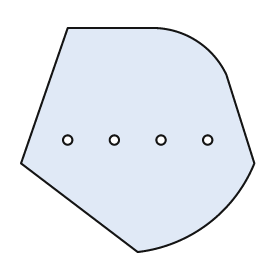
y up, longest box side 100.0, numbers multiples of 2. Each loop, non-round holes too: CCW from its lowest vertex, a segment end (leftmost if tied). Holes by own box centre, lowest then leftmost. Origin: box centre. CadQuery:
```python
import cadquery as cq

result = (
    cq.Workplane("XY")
    .moveTo(0.0, -48.0)
    .threePointArc((30.0, -36.0), (50.0, -10.0))
    .lineTo(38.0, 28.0)
    .threePointArc((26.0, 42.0), (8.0, 48.0))
    .lineTo(-30.0, 48.0)
    .lineTo(-50.0, -10.0)
    .close()
    .moveTo(-30.0, 0.0)
    .circle(2.0)
    .moveTo(-10.0, 0.0)
    .circle(2.0)
    .moveTo(10.0, 0.0)
    .circle(2.0)
    .moveTo(30.0, 0.0)
    .circle(2.0)
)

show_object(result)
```